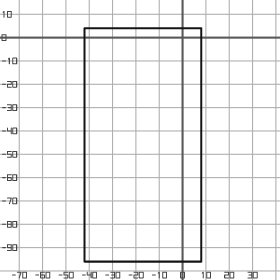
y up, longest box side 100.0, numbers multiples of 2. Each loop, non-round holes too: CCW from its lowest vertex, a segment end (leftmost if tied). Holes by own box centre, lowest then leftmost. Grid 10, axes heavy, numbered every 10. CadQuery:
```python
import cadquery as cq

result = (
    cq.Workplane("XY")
    .moveTo(-42.0, -96.0)
    .lineTo(8.0, -96.0)
    .lineTo(8.0, 4.0)
    .lineTo(-42.0, 4.0)
    .close()
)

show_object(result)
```